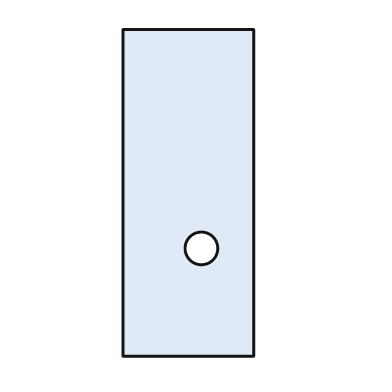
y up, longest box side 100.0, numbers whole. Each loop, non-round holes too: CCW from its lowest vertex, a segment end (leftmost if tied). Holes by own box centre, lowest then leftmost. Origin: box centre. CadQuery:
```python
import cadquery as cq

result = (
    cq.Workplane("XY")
    .moveTo(-20.0, -50.0)
    .lineTo(20.0, -50.0)
    .lineTo(20.0, 50.0)
    .lineTo(-20.0, 50.0)
    .close()
    .moveTo(4.0, -17.0)
    .circle(5.0)
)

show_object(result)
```